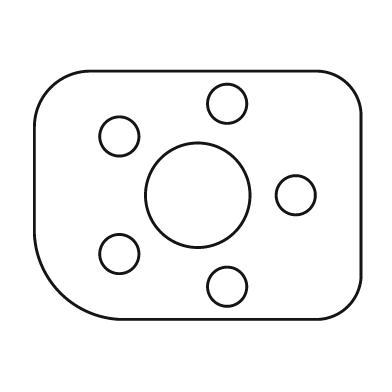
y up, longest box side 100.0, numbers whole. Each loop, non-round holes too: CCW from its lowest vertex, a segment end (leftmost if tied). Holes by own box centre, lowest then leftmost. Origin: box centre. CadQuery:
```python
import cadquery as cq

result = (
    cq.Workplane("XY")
    .moveTo(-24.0, -38.0)
    .lineTo(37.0, -38.0)
    .threePointArc((46.0, -34.0), (50.0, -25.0))
    .lineTo(50.0, 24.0)
    .threePointArc((46.0, 34.0), (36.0, 38.0))
    .lineTo(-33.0, 38.0)
    .threePointArc((-45.0, 33.0), (-50.0, 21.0))
    .lineTo(-50.0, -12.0)
    .threePointArc((-42.0, -30.0), (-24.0, -38.0))
    .close()
    .moveTo(9.0, -28.0)
    .circle(6.0)
    .moveTo(-24.0, -18.0)
    .circle(6.0)
    .moveTo(0.0, 0.0)
    .circle(16.0)
    .moveTo(30.0, 0.0)
    .circle(6.0)
    .moveTo(-24.0, 18.0)
    .circle(6.0)
    .moveTo(9.0, 28.0)
    .circle(6.0)
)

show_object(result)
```